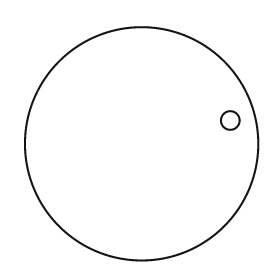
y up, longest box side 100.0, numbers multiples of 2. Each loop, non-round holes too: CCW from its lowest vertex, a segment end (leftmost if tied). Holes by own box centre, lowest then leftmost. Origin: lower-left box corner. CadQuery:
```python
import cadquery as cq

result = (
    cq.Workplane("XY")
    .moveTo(50.0, 50.0)
    .circle(50.0)
    .moveTo(88.0, 60.0)
    .circle(4.0)
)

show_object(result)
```